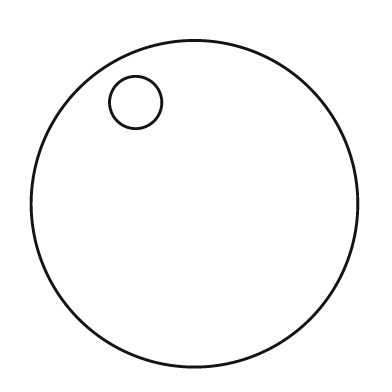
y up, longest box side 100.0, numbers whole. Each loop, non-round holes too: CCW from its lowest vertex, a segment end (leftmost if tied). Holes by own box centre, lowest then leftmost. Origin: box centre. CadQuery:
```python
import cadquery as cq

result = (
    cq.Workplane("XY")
    .moveTo(0.0, 0.0)
    .circle(50.0)
    .moveTo(-18.0, 31.0)
    .circle(8.0)
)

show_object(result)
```